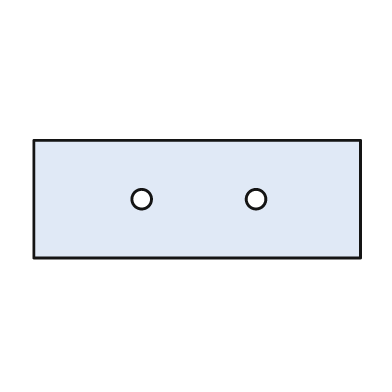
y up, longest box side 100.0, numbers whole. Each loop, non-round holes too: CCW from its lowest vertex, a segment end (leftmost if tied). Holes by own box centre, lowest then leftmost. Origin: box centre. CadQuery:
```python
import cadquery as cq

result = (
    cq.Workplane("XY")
    .moveTo(-50.0, -18.0)
    .lineTo(50.0, -18.0)
    .lineTo(50.0, 18.0)
    .lineTo(-50.0, 18.0)
    .close()
    .moveTo(-17.0, 0.0)
    .circle(3.0)
    .moveTo(18.0, 0.0)
    .circle(3.0)
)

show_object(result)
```